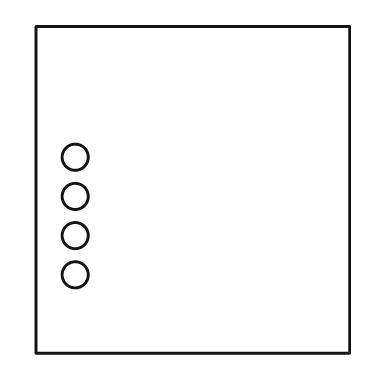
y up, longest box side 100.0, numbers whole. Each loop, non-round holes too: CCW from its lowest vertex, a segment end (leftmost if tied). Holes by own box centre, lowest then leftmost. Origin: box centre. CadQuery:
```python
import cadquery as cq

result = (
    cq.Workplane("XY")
    .moveTo(-48.0, -50.0)
    .lineTo(48.0, -50.0)
    .lineTo(48.0, 50.0)
    .lineTo(-48.0, 50.0)
    .close()
    .moveTo(-36.0, -26.0)
    .circle(4.0)
    .moveTo(-36.0, -14.0)
    .circle(4.0)
    .moveTo(-36.0, -2.0)
    .circle(4.0)
    .moveTo(-36.0, 10.0)
    .circle(4.0)
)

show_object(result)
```